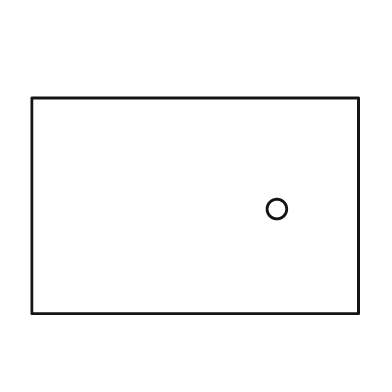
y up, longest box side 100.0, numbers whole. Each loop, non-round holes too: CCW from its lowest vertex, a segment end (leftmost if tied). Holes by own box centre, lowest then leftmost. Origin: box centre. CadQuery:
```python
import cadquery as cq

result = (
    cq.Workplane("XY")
    .moveTo(-50.0, -33.0)
    .lineTo(50.0, -33.0)
    .lineTo(50.0, 33.0)
    .lineTo(-50.0, 33.0)
    .close()
    .moveTo(25.0, -1.0)
    .circle(3.0)
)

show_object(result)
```